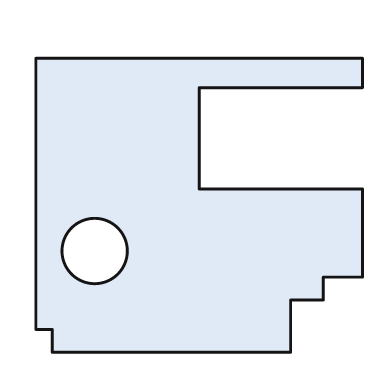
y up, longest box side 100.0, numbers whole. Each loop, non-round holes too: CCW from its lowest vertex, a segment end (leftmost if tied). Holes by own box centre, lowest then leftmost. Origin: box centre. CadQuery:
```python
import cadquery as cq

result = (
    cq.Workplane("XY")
    .moveTo(-45.0, -45.0)
    .lineTo(28.0, -45.0)
    .lineTo(28.0, -29.0)
    .lineTo(38.0, -29.0)
    .lineTo(38.0, -22.0)
    .lineTo(50.0, -22.0)
    .lineTo(50.0, 5.0)
    .lineTo(0.0, 5.0)
    .lineTo(0.0, 36.0)
    .lineTo(50.0, 36.0)
    .lineTo(50.0, 45.0)
    .lineTo(-50.0, 45.0)
    .lineTo(-50.0, -38.0)
    .lineTo(-45.0, -38.0)
    .close()
    .moveTo(-32.0, -14.0)
    .circle(10.0)
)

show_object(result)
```